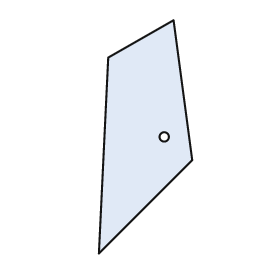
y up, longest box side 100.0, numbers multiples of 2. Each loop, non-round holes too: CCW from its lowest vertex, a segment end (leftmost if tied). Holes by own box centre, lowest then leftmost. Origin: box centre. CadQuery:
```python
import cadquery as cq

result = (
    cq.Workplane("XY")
    .moveTo(-20.0, -50.0)
    .lineTo(20.0, -10.0)
    .lineTo(12.0, 50.0)
    .lineTo(-16.0, 34.0)
    .close()
    .moveTo(8.0, 0.0)
    .circle(2.0)
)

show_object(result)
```